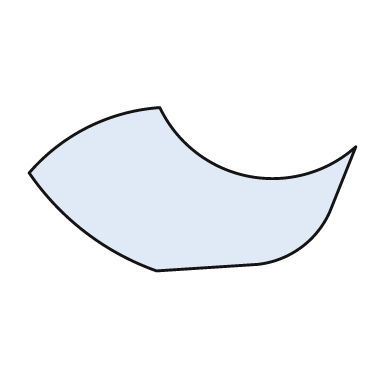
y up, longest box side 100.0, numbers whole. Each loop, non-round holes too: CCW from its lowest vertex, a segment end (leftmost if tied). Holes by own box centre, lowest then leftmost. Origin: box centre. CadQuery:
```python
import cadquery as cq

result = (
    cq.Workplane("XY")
    .moveTo(-11.0, -25.0)
    .lineTo(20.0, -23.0)
    .threePointArc((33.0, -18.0), (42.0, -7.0))
    .lineTo(50.0, 13.0)
    .threePointArc((17.0, 4.0), (-10.0, 25.0))
    .threePointArc((-32.0, 19.0), (-50.0, 5.0))
    .threePointArc((-33.0, -13.0), (-11.0, -25.0))
    .close()
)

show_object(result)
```